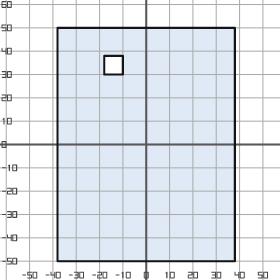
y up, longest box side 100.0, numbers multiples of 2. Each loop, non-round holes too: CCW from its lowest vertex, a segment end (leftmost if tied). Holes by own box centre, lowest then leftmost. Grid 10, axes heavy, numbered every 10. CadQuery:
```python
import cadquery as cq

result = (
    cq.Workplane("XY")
    .moveTo(-38.0, -50.0)
    .lineTo(38.0, -50.0)
    .lineTo(38.0, 50.0)
    .lineTo(-38.0, 50.0)
    .close()
    .moveTo(-18.0, 30.0)
    .lineTo(-10.0, 30.0)
    .lineTo(-10.0, 38.0)
    .lineTo(-18.0, 38.0)
    .close()
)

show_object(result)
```